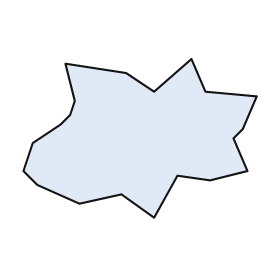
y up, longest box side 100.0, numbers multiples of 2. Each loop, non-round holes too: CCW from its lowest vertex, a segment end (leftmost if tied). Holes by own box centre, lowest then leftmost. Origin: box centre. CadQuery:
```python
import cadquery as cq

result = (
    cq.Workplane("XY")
    .moveTo(6.0, -34.0)
    .lineTo(16.0, -16.0)
    .lineTo(30.0, -18.0)
    .lineTo(46.0, -14.0)
    .lineTo(40.0, 0.0)
    .lineTo(44.0, 4.0)
    .lineTo(50.0, 18.0)
    .lineTo(28.0, 20.0)
    .lineTo(22.0, 34.0)
    .lineTo(6.0, 20.0)
    .lineTo(-6.0, 28.0)
    .lineTo(-32.0, 32.0)
    .lineTo(-28.0, 16.0)
    .lineTo(-30.0, 10.0)
    .lineTo(-34.0, 6.0)
    .lineTo(-46.0, -2.0)
    .lineTo(-50.0, -14.0)
    .lineTo(-44.0, -20.0)
    .lineTo(-26.0, -28.0)
    .lineTo(-8.0, -24.0)
    .close()
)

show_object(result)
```